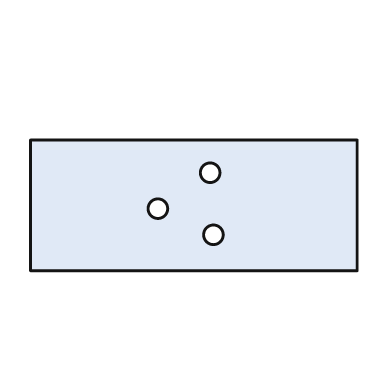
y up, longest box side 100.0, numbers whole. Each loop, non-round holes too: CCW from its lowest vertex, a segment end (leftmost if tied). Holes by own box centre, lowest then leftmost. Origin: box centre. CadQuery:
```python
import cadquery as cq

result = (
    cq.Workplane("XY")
    .moveTo(-50.0, -20.0)
    .lineTo(50.0, -20.0)
    .lineTo(50.0, 20.0)
    .lineTo(-50.0, 20.0)
    .close()
    .moveTo(6.0, -9.0)
    .circle(3.0)
    .moveTo(-11.0, -1.0)
    .circle(3.0)
    .moveTo(5.0, 10.0)
    .circle(3.0)
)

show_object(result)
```